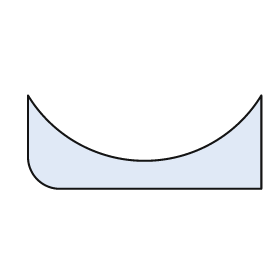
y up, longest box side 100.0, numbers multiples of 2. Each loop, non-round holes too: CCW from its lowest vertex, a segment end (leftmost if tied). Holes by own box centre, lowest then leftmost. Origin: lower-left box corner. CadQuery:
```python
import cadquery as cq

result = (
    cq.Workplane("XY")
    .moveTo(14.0, 0.0)
    .lineTo(100.0, 0.0)
    .lineTo(100.0, 40.0)
    .threePointArc((50.0, 12.0), (0.0, 40.0))
    .lineTo(0.0, 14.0)
    .threePointArc((4.0, 4.0), (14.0, 0.0))
    .close()
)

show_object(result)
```